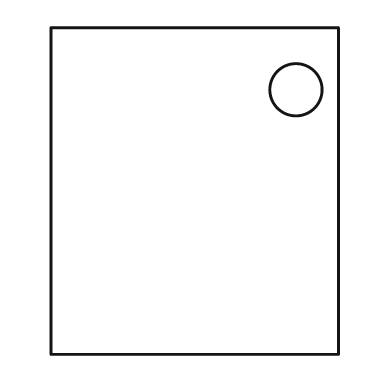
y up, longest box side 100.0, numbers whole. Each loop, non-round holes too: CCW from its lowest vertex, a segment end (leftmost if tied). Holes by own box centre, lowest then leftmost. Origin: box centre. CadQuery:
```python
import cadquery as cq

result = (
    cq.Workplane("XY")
    .moveTo(-44.0, -50.0)
    .lineTo(44.0, -50.0)
    .lineTo(44.0, 50.0)
    .lineTo(-44.0, 50.0)
    .close()
    .moveTo(31.0, 31.0)
    .circle(8.0)
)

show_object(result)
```